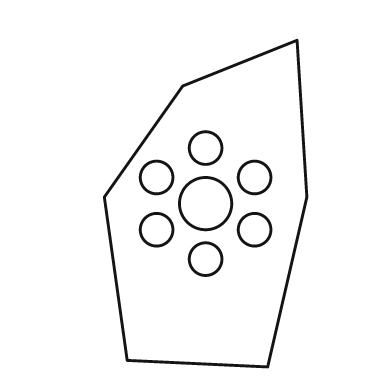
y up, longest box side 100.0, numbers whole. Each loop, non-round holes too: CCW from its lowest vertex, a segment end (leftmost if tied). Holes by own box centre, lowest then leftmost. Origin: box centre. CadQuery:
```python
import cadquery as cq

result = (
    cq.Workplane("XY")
    .moveTo(19.0, -50.0)
    .lineTo(31.0, 2.0)
    .lineTo(28.0, 50.0)
    .lineTo(-7.0, 36.0)
    .lineTo(-31.0, 2.0)
    .lineTo(-24.0, -48.0)
    .close()
    .moveTo(0.0, -17.0)
    .circle(5.0)
    .moveTo(-15.0, -8.0)
    .circle(5.0)
    .moveTo(15.0, -8.0)
    .circle(5.0)
    .moveTo(0.0, 0.0)
    .circle(8.0)
    .moveTo(-15.0, 8.0)
    .circle(5.0)
    .moveTo(15.0, 8.0)
    .circle(5.0)
    .moveTo(0.0, 17.0)
    .circle(5.0)
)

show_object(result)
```